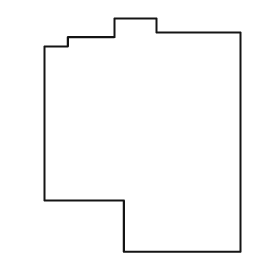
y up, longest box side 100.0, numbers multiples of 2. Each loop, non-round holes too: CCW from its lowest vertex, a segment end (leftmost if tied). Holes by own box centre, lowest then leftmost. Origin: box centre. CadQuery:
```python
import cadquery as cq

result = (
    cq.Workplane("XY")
    .moveTo(-8.0, -50.0)
    .lineTo(42.0, -50.0)
    .lineTo(42.0, 44.0)
    .lineTo(6.0, 44.0)
    .lineTo(6.0, 50.0)
    .lineTo(-12.0, 50.0)
    .lineTo(-12.0, 42.0)
    .lineTo(-32.0, 42.0)
    .lineTo(-32.0, 38.0)
    .lineTo(-42.0, 38.0)
    .lineTo(-42.0, -28.0)
    .lineTo(-8.0, -28.0)
    .close()
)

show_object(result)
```